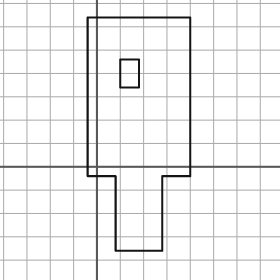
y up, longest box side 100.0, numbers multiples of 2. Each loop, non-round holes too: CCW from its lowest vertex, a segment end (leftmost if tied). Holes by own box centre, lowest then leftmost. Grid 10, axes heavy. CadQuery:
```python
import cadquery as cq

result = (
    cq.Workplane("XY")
    .moveTo(8.0, -36.0)
    .lineTo(28.0, -36.0)
    .lineTo(28.0, -4.0)
    .lineTo(40.0, -4.0)
    .lineTo(40.0, 64.0)
    .lineTo(-4.0, 64.0)
    .lineTo(-4.0, -4.0)
    .lineTo(8.0, -4.0)
    .close()
    .moveTo(10.0, 34.0)
    .lineTo(18.0, 34.0)
    .lineTo(18.0, 46.0)
    .lineTo(10.0, 46.0)
    .close()
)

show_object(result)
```